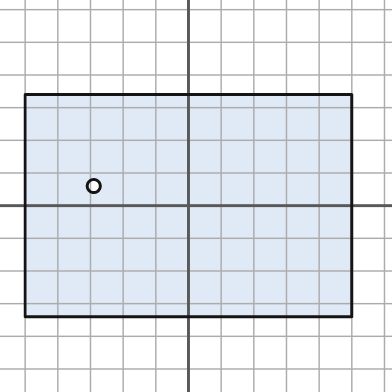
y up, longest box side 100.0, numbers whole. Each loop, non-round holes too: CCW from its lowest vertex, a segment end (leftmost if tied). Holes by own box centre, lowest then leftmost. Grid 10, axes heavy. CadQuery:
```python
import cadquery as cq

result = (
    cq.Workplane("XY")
    .moveTo(-50.0, -34.0)
    .lineTo(50.0, -34.0)
    .lineTo(50.0, 34.0)
    .lineTo(-50.0, 34.0)
    .close()
    .moveTo(-29.0, 6.0)
    .circle(2.0)
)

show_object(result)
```